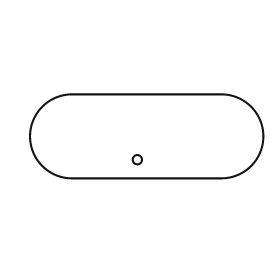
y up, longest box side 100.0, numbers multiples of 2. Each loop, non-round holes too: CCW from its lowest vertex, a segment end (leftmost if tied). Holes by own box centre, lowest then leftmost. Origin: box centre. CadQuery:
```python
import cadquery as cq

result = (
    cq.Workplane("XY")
    .moveTo(-32.0, -18.0)
    .lineTo(32.0, -18.0)
    .threePointArc((50.0, 0.0), (32.0, 18.0))
    .lineTo(-32.0, 18.0)
    .threePointArc((-50.0, 0.0), (-32.0, -18.0))
    .close()
    .moveTo(-4.0, -10.0)
    .circle(2.0)
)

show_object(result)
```